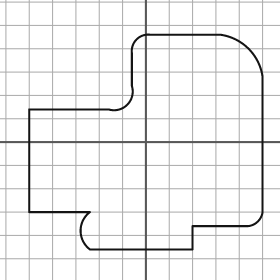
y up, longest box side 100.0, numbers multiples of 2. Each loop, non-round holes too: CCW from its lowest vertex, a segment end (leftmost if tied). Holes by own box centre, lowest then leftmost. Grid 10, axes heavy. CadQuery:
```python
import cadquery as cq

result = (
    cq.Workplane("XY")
    .moveTo(-24.0, -46.0)
    .lineTo(20.0, -46.0)
    .lineTo(20.0, -36.0)
    .lineTo(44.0, -36.0)
    .threePointArc((48.0, -34.0), (50.0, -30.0))
    .lineTo(50.0, 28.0)
    .threePointArc((44.0, 40.0), (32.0, 46.0))
    .lineTo(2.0, 46.0)
    .threePointArc((-4.0, 44.0), (-6.0, 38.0))
    .lineTo(-6.0, 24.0)
    .threePointArc((-8.0, 16.0), (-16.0, 14.0))
    .lineTo(-50.0, 14.0)
    .lineTo(-50.0, -30.0)
    .lineTo(-24.0, -30.0)
    .threePointArc((-28.0, -38.0), (-24.0, -46.0))
    .close()
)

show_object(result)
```